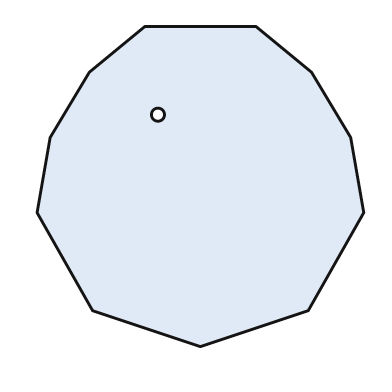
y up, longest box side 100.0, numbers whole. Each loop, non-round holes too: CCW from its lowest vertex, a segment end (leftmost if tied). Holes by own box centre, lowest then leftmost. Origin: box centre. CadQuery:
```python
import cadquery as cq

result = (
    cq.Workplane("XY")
    .moveTo(0.0, -49.0)
    .lineTo(33.0, -38.0)
    .lineTo(50.0, -8.0)
    .lineTo(46.0, 15.0)
    .lineTo(34.0, 35.0)
    .lineTo(17.0, 49.0)
    .lineTo(-17.0, 49.0)
    .lineTo(-34.0, 35.0)
    .lineTo(-46.0, 15.0)
    .lineTo(-50.0, -8.0)
    .lineTo(-33.0, -38.0)
    .close()
    .moveTo(-13.0, 22.0)
    .circle(2.0)
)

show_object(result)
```